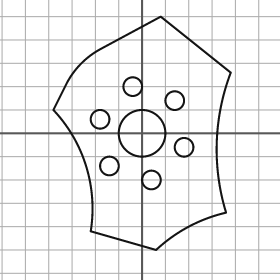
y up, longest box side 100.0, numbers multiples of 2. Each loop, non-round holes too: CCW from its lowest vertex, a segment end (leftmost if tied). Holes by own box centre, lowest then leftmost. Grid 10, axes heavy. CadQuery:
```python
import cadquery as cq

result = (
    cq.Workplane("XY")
    .moveTo(6.0, -50.0)
    .threePointArc((20.0, -40.0), (36.0, -34.0))
    .threePointArc((32.0, -4.0), (38.0, 26.0))
    .lineTo(8.0, 50.0)
    .lineTo(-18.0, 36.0)
    .threePointArc((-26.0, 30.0), (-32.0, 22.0))
    .lineTo(-38.0, 10.0)
    .threePointArc((-24.0, -14.0), (-22.0, -42.0))
    .close()
    .moveTo(4.0, -20.0)
    .circle(4.0)
    .moveTo(-14.0, -14.0)
    .circle(4.0)
    .moveTo(18.0, -6.0)
    .circle(4.0)
    .moveTo(0.0, 0.0)
    .circle(10.0)
    .moveTo(-18.0, 6.0)
    .circle(4.0)
    .moveTo(14.0, 14.0)
    .circle(4.0)
    .moveTo(-4.0, 20.0)
    .circle(4.0)
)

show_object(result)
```